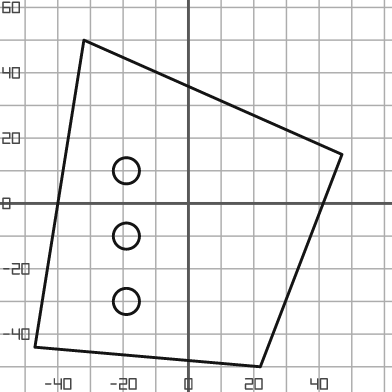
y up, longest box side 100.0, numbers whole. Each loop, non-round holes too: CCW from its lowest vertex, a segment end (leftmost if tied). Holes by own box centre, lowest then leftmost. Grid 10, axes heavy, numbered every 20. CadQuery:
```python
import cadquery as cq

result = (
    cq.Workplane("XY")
    .moveTo(22.0, -50.0)
    .lineTo(47.0, 15.0)
    .lineTo(-32.0, 50.0)
    .lineTo(-47.0, -44.0)
    .close()
    .moveTo(-19.0, -30.0)
    .circle(4.0)
    .moveTo(-19.0, -10.0)
    .circle(4.0)
    .moveTo(-19.0, 10.0)
    .circle(4.0)
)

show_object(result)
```